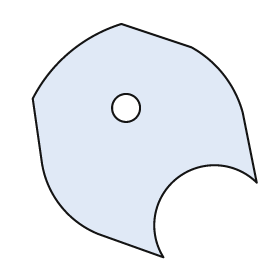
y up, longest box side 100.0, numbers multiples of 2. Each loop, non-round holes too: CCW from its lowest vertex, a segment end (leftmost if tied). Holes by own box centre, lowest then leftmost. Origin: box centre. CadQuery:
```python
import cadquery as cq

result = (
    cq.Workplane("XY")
    .moveTo(8.0, -50.0)
    .threePointArc((14.0, -16.0), (48.0, -18.0))
    .lineTo(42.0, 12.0)
    .threePointArc((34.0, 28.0), (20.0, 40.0))
    .lineTo(-10.0, 50.0)
    .threePointArc((-32.0, 38.0), (-48.0, 18.0))
    .lineTo(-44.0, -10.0)
    .threePointArc((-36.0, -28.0), (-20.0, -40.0))
    .close()
    .moveTo(-8.0, 14.0)
    .circle(6.0)
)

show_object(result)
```